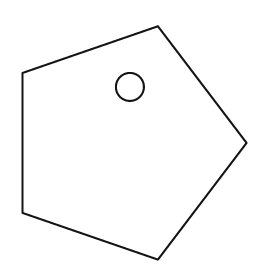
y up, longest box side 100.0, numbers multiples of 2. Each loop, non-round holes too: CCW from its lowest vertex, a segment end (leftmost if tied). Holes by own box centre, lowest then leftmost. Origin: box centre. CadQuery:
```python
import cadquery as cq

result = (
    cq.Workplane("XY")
    .moveTo(10.0, -50.0)
    .lineTo(48.0, 0.0)
    .lineTo(10.0, 50.0)
    .lineTo(-48.0, 30.0)
    .lineTo(-48.0, -30.0)
    .close()
    .moveTo(-2.0, 24.0)
    .circle(6.0)
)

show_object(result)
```